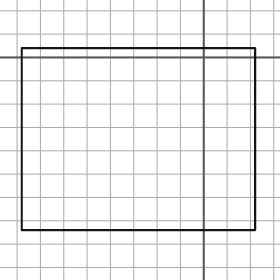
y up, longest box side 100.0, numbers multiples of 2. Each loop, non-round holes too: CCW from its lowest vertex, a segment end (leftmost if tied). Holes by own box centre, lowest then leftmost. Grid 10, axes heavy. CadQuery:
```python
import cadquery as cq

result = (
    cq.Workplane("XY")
    .moveTo(-78.0, -74.0)
    .lineTo(22.0, -74.0)
    .lineTo(22.0, 4.0)
    .lineTo(-78.0, 4.0)
    .close()
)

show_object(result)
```